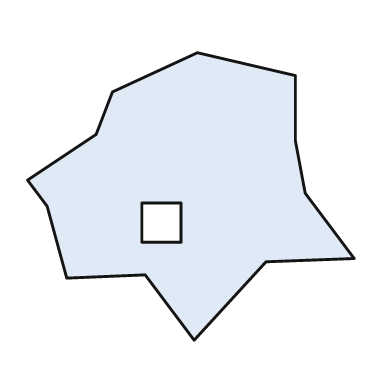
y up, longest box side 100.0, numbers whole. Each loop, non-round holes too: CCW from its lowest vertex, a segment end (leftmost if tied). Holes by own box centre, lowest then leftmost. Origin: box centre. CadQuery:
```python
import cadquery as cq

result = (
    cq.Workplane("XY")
    .moveTo(1.0, -44.0)
    .lineTo(23.0, -20.0)
    .lineTo(50.0, -19.0)
    .lineTo(35.0, 1.0)
    .lineTo(32.0, 17.0)
    .lineTo(32.0, 37.0)
    .lineTo(2.0, 44.0)
    .lineTo(-24.0, 32.0)
    .lineTo(-29.0, 19.0)
    .lineTo(-50.0, 5.0)
    .lineTo(-44.0, -3.0)
    .lineTo(-38.0, -25.0)
    .lineTo(-14.0, -24.0)
    .close()
    .moveTo(-15.0, -14.0)
    .lineTo(-3.0, -14.0)
    .lineTo(-3.0, -2.0)
    .lineTo(-15.0, -2.0)
    .close()
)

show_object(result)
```